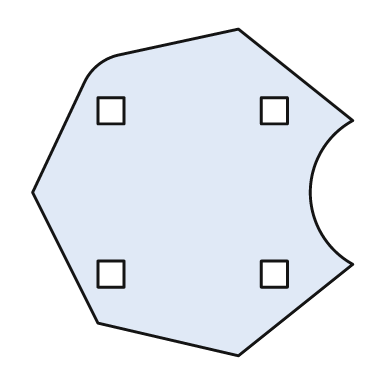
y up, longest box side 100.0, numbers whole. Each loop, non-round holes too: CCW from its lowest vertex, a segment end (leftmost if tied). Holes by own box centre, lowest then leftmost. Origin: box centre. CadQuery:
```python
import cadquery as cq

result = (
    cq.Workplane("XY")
    .moveTo(14.0, -50.0)
    .lineTo(49.0, -22.0)
    .threePointArc((36.0, 0.0), (49.0, 22.0))
    .lineTo(14.0, 50.0)
    .lineTo(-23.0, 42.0)
    .threePointArc((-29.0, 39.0), (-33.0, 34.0))
    .lineTo(-49.0, 0.0)
    .lineTo(-29.0, -40.0)
    .close()
    .moveTo(-29.0, -29.0)
    .lineTo(-21.0, -29.0)
    .lineTo(-21.0, -21.0)
    .lineTo(-29.0, -21.0)
    .close()
    .moveTo(21.0, -29.0)
    .lineTo(29.0, -29.0)
    .lineTo(29.0, -21.0)
    .lineTo(21.0, -21.0)
    .close()
    .moveTo(-29.0, 21.0)
    .lineTo(-21.0, 21.0)
    .lineTo(-21.0, 29.0)
    .lineTo(-29.0, 29.0)
    .close()
    .moveTo(21.0, 21.0)
    .lineTo(29.0, 21.0)
    .lineTo(29.0, 29.0)
    .lineTo(21.0, 29.0)
    .close()
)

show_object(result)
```